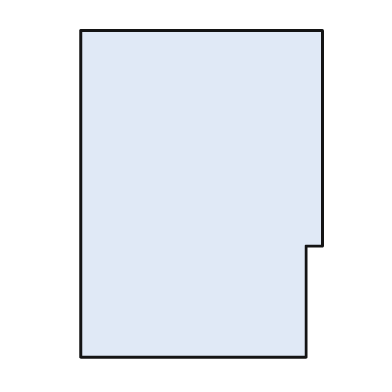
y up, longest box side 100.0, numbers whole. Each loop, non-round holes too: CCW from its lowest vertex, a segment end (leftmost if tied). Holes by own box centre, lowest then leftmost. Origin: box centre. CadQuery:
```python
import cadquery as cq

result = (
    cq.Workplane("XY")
    .moveTo(-37.0, -50.0)
    .lineTo(32.0, -50.0)
    .lineTo(32.0, -16.0)
    .lineTo(37.0, -16.0)
    .lineTo(37.0, 50.0)
    .lineTo(-37.0, 50.0)
    .close()
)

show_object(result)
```